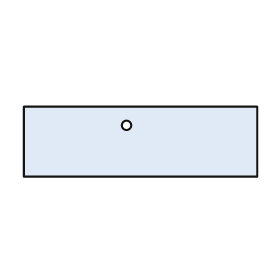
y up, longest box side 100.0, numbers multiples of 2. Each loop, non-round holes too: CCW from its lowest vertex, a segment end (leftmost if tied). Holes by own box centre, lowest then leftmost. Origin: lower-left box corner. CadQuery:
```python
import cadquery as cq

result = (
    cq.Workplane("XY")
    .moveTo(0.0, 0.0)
    .lineTo(100.0, 0.0)
    .lineTo(100.0, 30.0)
    .lineTo(0.0, 30.0)
    .close()
    .moveTo(44.0, 22.0)
    .circle(2.0)
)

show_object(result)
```